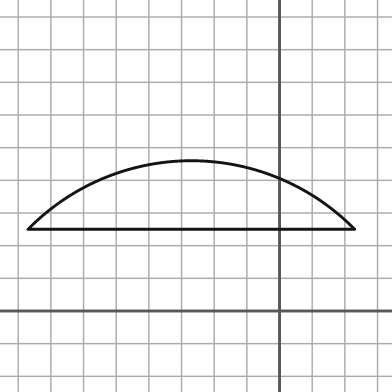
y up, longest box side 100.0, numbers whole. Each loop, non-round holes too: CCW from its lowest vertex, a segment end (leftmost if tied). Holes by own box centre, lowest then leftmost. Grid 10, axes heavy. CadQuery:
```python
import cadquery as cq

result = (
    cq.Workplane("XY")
    .moveTo(-77.0, 25.0)
    .lineTo(23.0, 25.0)
    .threePointArc((-27.0, 46.0), (-77.0, 25.0))
    .close()
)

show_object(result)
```